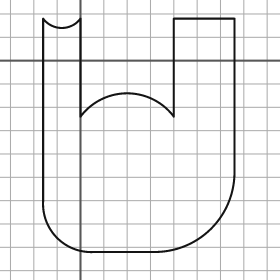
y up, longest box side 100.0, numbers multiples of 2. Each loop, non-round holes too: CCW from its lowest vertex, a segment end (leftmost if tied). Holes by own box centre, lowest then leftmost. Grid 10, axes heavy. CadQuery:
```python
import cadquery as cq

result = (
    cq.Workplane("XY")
    .moveTo(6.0, -82.0)
    .lineTo(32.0, -82.0)
    .threePointArc((56.0, -72.0), (66.0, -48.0))
    .lineTo(66.0, 18.0)
    .lineTo(40.0, 18.0)
    .lineTo(40.0, -24.0)
    .threePointArc((20.0, -14.0), (0.0, -24.0))
    .lineTo(0.0, 18.0)
    .threePointArc((-8.0, 14.0), (-16.0, 18.0))
    .lineTo(-16.0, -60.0)
    .threePointArc((-10.0, -76.0), (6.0, -82.0))
    .close()
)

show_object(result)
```